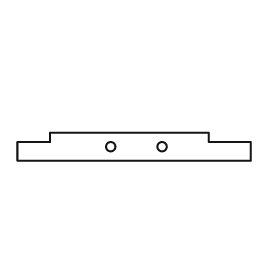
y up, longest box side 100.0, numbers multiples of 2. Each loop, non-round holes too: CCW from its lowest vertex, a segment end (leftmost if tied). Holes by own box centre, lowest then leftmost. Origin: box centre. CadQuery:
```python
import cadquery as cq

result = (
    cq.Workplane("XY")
    .moveTo(-50.0, -6.0)
    .lineTo(50.0, -6.0)
    .lineTo(50.0, 2.0)
    .lineTo(32.0, 2.0)
    .lineTo(32.0, 6.0)
    .lineTo(-36.0, 6.0)
    .lineTo(-36.0, 2.0)
    .lineTo(-50.0, 2.0)
    .close()
    .moveTo(-10.0, 0.0)
    .circle(2.0)
    .moveTo(12.0, 0.0)
    .circle(2.0)
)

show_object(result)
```